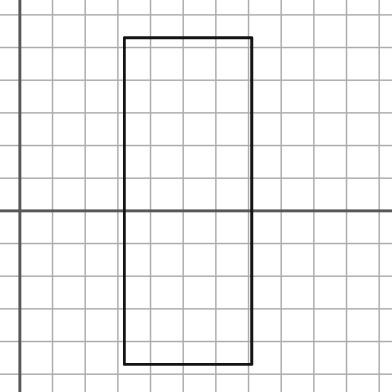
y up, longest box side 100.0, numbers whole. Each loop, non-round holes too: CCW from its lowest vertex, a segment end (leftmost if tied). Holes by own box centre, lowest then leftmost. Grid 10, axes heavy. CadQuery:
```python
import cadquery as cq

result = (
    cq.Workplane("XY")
    .moveTo(32.0, -47.0)
    .lineTo(71.0, -47.0)
    .lineTo(71.0, 53.0)
    .lineTo(32.0, 53.0)
    .close()
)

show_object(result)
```